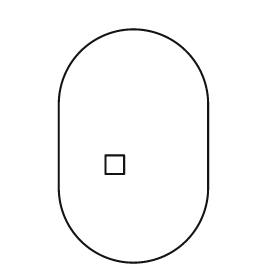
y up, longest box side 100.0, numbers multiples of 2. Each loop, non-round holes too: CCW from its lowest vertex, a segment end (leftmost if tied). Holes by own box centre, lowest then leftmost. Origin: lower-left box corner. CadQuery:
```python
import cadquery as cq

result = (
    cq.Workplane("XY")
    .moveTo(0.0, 32.0)
    .threePointArc((32.0, 0.0), (64.0, 32.0))
    .lineTo(64.0, 68.0)
    .threePointArc((32.0, 100.0), (0.0, 68.0))
    .close()
    .moveTo(20.0, 38.0)
    .lineTo(28.0, 38.0)
    .lineTo(28.0, 46.0)
    .lineTo(20.0, 46.0)
    .close()
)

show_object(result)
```